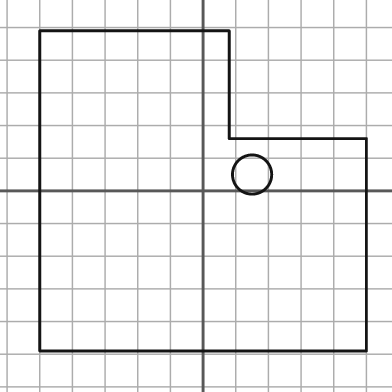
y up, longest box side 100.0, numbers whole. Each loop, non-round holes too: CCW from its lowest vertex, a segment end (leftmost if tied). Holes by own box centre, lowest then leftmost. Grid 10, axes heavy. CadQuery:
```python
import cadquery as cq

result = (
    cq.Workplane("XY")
    .moveTo(-50.0, -49.0)
    .lineTo(50.0, -49.0)
    .lineTo(50.0, 16.0)
    .lineTo(8.0, 16.0)
    .lineTo(8.0, 49.0)
    .lineTo(-50.0, 49.0)
    .close()
    .moveTo(15.0, 5.0)
    .circle(6.0)
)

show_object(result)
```